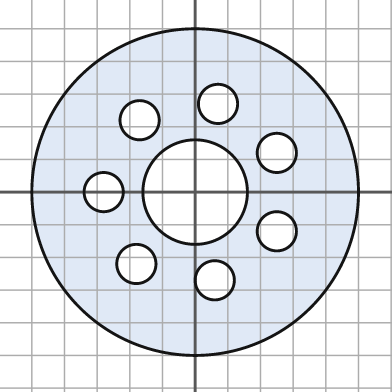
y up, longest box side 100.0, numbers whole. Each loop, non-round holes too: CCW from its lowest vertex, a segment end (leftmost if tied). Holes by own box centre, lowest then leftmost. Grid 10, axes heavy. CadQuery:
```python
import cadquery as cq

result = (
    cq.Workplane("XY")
    .moveTo(0.0, 0.0)
    .circle(50.0)
    .moveTo(6.0, -27.0)
    .circle(6.0)
    .moveTo(-18.0, -22.0)
    .circle(6.0)
    .moveTo(25.0, -12.0)
    .circle(6.0)
    .moveTo(-28.0, 0.0)
    .circle(6.0)
    .moveTo(0.0, 0.0)
    .circle(16.0)
    .moveTo(25.0, 12.0)
    .circle(6.0)
    .moveTo(-17.0, 22.0)
    .circle(6.0)
    .moveTo(7.0, 27.0)
    .circle(6.0)
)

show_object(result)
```